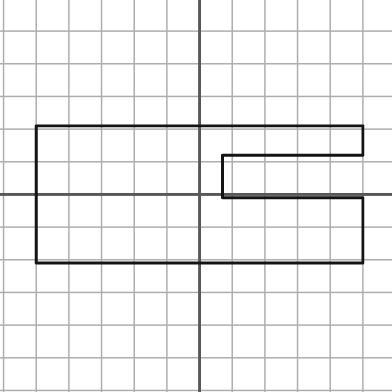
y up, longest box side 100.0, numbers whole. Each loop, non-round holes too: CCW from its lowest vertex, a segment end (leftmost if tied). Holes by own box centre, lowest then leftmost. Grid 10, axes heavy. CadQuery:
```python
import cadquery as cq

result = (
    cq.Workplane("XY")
    .moveTo(-50.0, -21.0)
    .lineTo(50.0, -21.0)
    .lineTo(50.0, -1.0)
    .lineTo(7.0, -1.0)
    .lineTo(7.0, 12.0)
    .lineTo(50.0, 12.0)
    .lineTo(50.0, 21.0)
    .lineTo(-50.0, 21.0)
    .close()
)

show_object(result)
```